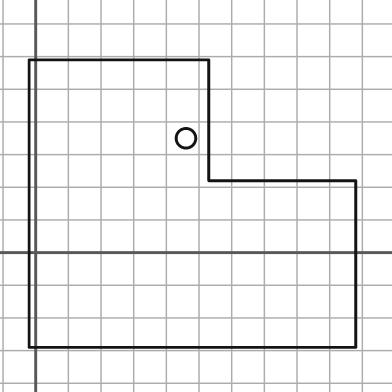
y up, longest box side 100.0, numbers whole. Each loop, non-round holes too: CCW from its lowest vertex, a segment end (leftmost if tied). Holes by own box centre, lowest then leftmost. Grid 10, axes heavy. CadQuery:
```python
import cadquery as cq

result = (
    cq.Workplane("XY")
    .moveTo(-2.0, -29.0)
    .lineTo(98.0, -29.0)
    .lineTo(98.0, 22.0)
    .lineTo(53.0, 22.0)
    .lineTo(53.0, 59.0)
    .lineTo(-2.0, 59.0)
    .close()
    .moveTo(46.0, 35.0)
    .circle(3.0)
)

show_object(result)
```